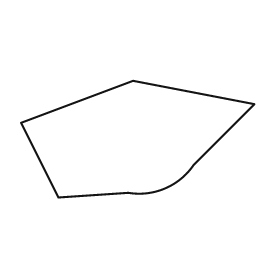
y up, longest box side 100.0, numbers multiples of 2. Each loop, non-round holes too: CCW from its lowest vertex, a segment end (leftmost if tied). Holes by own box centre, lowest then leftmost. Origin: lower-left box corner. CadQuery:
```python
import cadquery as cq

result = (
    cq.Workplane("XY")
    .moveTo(16.0, 0.0)
    .lineTo(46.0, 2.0)
    .threePointArc((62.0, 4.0), (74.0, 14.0))
    .lineTo(100.0, 40.0)
    .lineTo(48.0, 50.0)
    .lineTo(0.0, 32.0)
    .close()
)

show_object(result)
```